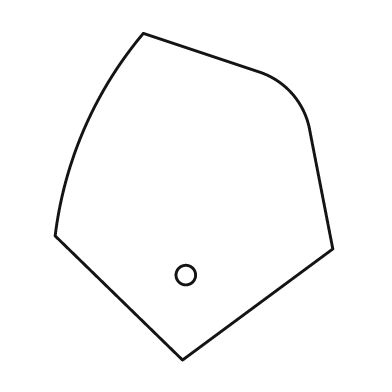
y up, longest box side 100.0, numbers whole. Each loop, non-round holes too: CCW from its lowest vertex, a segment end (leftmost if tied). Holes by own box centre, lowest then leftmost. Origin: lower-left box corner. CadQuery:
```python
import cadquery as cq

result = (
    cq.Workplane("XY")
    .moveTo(39.0, 0.0)
    .lineTo(85.0, 34.0)
    .lineTo(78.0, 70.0)
    .threePointArc((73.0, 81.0), (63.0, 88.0))
    .lineTo(27.0, 100.0)
    .threePointArc((9.0, 71.0), (0.0, 38.0))
    .close()
    .moveTo(40.0, 26.0)
    .circle(3.0)
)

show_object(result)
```